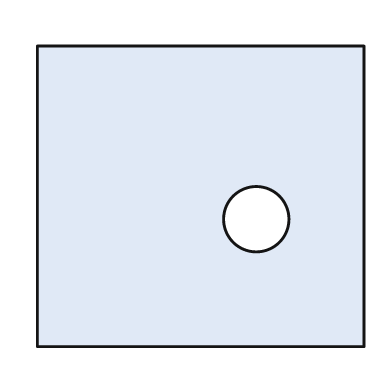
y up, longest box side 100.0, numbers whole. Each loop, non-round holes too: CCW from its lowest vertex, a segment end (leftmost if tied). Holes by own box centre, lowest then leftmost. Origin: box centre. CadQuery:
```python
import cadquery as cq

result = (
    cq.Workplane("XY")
    .moveTo(-50.0, -46.0)
    .lineTo(50.0, -46.0)
    .lineTo(50.0, 46.0)
    .lineTo(-50.0, 46.0)
    .close()
    .moveTo(17.0, -7.0)
    .circle(10.0)
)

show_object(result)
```